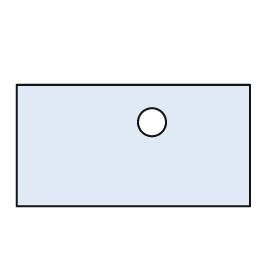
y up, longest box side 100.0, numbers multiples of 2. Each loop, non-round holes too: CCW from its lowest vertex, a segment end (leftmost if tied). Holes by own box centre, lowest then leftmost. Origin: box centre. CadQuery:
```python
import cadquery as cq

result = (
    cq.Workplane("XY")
    .moveTo(-50.0, -26.0)
    .lineTo(50.0, -26.0)
    .lineTo(50.0, 26.0)
    .lineTo(-50.0, 26.0)
    .close()
    .moveTo(8.0, 10.0)
    .circle(6.0)
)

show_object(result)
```